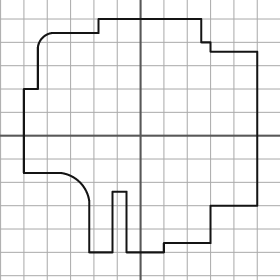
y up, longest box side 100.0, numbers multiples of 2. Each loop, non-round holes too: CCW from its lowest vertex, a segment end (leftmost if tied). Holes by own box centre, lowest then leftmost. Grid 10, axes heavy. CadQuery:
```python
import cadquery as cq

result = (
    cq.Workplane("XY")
    .moveTo(-22.0, -50.0)
    .lineTo(-12.0, -50.0)
    .lineTo(-12.0, -24.0)
    .lineTo(-6.0, -24.0)
    .lineTo(-6.0, -50.0)
    .lineTo(10.0, -50.0)
    .lineTo(10.0, -46.0)
    .lineTo(30.0, -46.0)
    .lineTo(30.0, -30.0)
    .lineTo(50.0, -30.0)
    .lineTo(50.0, 36.0)
    .lineTo(30.0, 36.0)
    .lineTo(30.0, 40.0)
    .lineTo(26.0, 40.0)
    .lineTo(26.0, 50.0)
    .lineTo(-18.0, 50.0)
    .lineTo(-18.0, 44.0)
    .lineTo(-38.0, 44.0)
    .threePointArc((-42.0, 42.0), (-44.0, 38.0))
    .lineTo(-44.0, 20.0)
    .lineTo(-50.0, 20.0)
    .lineTo(-50.0, -16.0)
    .lineTo(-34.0, -16.0)
    .threePointArc((-26.0, -20.0), (-22.0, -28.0))
    .close()
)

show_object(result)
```